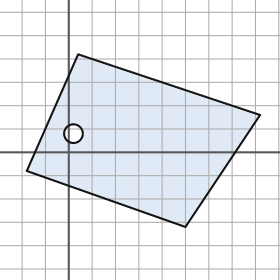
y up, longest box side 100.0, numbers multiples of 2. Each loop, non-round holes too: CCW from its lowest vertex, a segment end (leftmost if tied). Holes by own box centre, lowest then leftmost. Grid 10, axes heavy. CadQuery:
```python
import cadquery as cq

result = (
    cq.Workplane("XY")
    .moveTo(50.0, -32.0)
    .lineTo(82.0, 16.0)
    .lineTo(4.0, 42.0)
    .lineTo(-18.0, -8.0)
    .close()
    .moveTo(2.0, 8.0)
    .circle(4.0)
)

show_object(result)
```